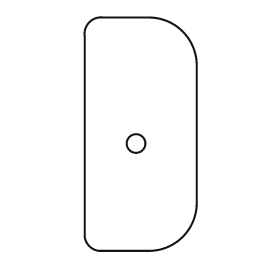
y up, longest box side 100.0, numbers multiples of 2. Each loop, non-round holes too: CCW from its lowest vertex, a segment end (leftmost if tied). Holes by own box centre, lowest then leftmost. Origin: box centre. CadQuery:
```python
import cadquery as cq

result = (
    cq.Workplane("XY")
    .moveTo(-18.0, -50.0)
    .lineTo(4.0, -50.0)
    .threePointArc((18.0, -44.0), (24.0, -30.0))
    .lineTo(24.0, 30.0)
    .threePointArc((18.0, 44.0), (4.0, 50.0))
    .lineTo(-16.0, 50.0)
    .threePointArc((-22.0, 48.0), (-24.0, 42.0))
    .lineTo(-24.0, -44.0)
    .threePointArc((-22.0, -48.0), (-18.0, -50.0))
    .close()
    .moveTo(-2.0, -4.0)
    .circle(4.0)
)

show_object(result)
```